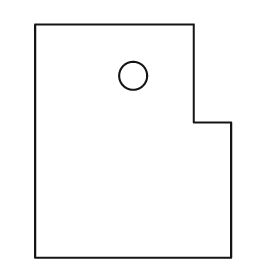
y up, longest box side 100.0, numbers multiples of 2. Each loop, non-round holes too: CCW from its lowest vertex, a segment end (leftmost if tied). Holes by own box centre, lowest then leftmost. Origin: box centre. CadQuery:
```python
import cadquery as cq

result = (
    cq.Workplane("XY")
    .moveTo(-42.0, -50.0)
    .lineTo(42.0, -50.0)
    .lineTo(42.0, 8.0)
    .lineTo(26.0, 8.0)
    .lineTo(26.0, 50.0)
    .lineTo(-42.0, 50.0)
    .close()
    .moveTo(0.0, 28.0)
    .circle(6.0)
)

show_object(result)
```